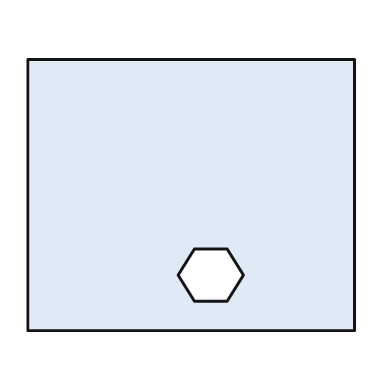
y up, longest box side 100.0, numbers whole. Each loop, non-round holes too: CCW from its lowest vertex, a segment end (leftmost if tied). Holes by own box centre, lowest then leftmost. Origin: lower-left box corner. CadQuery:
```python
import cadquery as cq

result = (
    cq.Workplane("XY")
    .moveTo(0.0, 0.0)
    .lineTo(100.0, 0.0)
    .lineTo(100.0, 83.0)
    .lineTo(0.0, 83.0)
    .close()
    .moveTo(51.0, 9.0)
    .lineTo(61.0, 9.0)
    .lineTo(66.0, 17.0)
    .lineTo(61.0, 25.0)
    .lineTo(51.0, 25.0)
    .lineTo(46.0, 17.0)
    .close()
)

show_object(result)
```